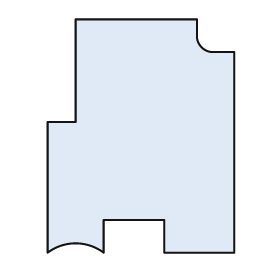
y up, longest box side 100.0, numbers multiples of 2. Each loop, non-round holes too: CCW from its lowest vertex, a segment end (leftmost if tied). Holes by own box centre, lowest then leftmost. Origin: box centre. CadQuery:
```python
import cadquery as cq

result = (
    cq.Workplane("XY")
    .moveTo(-40.0, -50.0)
    .threePointArc((-28.0, -46.0), (-16.0, -50.0))
    .lineTo(-16.0, -36.0)
    .lineTo(10.0, -36.0)
    .lineTo(10.0, -50.0)
    .lineTo(40.0, -50.0)
    .lineTo(40.0, 36.0)
    .lineTo(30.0, 36.0)
    .threePointArc((26.0, 38.0), (24.0, 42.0))
    .lineTo(24.0, 50.0)
    .lineTo(-28.0, 50.0)
    .lineTo(-28.0, 6.0)
    .lineTo(-40.0, 6.0)
    .close()
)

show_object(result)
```